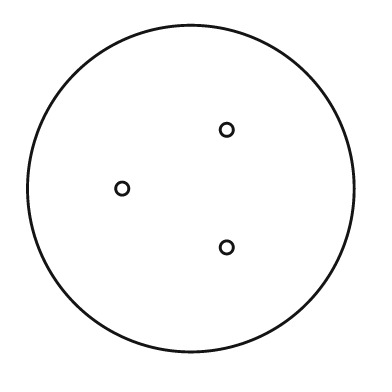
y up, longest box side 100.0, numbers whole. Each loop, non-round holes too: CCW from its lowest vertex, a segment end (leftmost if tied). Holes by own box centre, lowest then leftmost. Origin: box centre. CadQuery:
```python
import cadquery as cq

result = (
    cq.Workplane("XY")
    .moveTo(0.0, 0.0)
    .circle(50.0)
    .moveTo(11.0, -18.0)
    .circle(2.0)
    .moveTo(-21.0, 0.0)
    .circle(2.0)
    .moveTo(11.0, 18.0)
    .circle(2.0)
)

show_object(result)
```